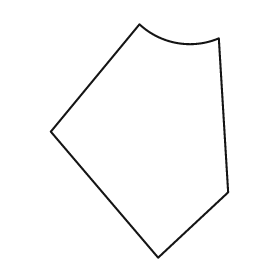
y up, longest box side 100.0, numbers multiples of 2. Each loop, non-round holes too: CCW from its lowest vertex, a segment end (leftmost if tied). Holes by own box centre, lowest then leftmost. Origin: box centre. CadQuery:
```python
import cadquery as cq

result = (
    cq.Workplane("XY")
    .moveTo(8.0, -50.0)
    .lineTo(38.0, -22.0)
    .lineTo(34.0, 44.0)
    .threePointArc((16.0, 42.0), (0.0, 50.0))
    .lineTo(-38.0, 4.0)
    .close()
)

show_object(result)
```